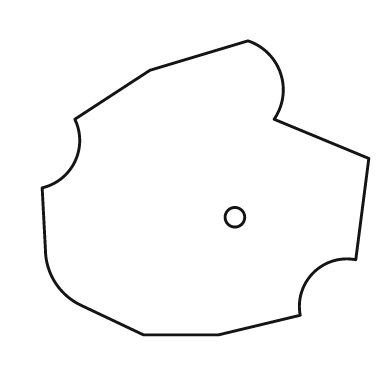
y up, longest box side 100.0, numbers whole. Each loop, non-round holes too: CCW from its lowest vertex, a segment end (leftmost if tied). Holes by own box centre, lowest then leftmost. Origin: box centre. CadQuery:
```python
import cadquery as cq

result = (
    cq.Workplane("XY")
    .moveTo(-19.0, -45.0)
    .lineTo(4.0, -45.0)
    .lineTo(29.0, -39.0)
    .threePointArc((33.0, -26.0), (46.0, -22.0))
    .lineTo(50.0, 9.0)
    .lineTo(21.0, 21.0)
    .threePointArc((23.0, 35.0), (13.0, 45.0))
    .lineTo(-17.0, 36.0)
    .lineTo(-40.0, 21.0)
    .threePointArc((-40.0, 8.0), (-50.0, 0.0))
    .lineTo(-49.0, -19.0)
    .threePointArc((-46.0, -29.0), (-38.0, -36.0))
    .close()
    .moveTo(9.0, -9.0)
    .circle(3.0)
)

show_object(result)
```